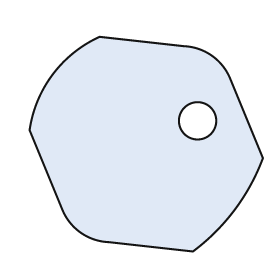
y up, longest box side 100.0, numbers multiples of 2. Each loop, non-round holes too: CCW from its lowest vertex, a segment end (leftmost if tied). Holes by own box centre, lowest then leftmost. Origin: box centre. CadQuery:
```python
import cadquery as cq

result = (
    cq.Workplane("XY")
    .moveTo(20.0, -46.0)
    .threePointArc((38.0, -28.0), (50.0, -6.0))
    .lineTo(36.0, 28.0)
    .threePointArc((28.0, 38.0), (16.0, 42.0))
    .lineTo(-20.0, 46.0)
    .threePointArc((-40.0, 30.0), (-50.0, 6.0))
    .lineTo(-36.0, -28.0)
    .threePointArc((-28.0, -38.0), (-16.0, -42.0))
    .close()
    .moveTo(22.0, 10.0)
    .circle(8.0)
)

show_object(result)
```